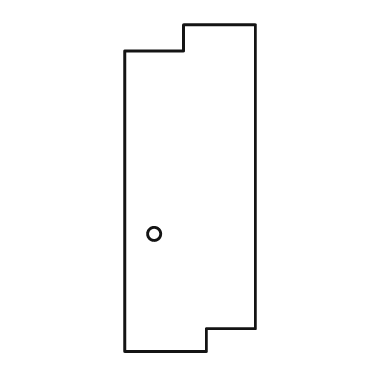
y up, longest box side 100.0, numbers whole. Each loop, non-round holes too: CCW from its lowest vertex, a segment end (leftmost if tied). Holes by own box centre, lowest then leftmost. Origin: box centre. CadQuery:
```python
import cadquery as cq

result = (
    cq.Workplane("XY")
    .moveTo(-20.0, -50.0)
    .lineTo(5.0, -50.0)
    .lineTo(5.0, -43.0)
    .lineTo(20.0, -43.0)
    .lineTo(20.0, 50.0)
    .lineTo(-2.0, 50.0)
    .lineTo(-2.0, 42.0)
    .lineTo(-20.0, 42.0)
    .close()
    .moveTo(-11.0, -14.0)
    .circle(2.0)
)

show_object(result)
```